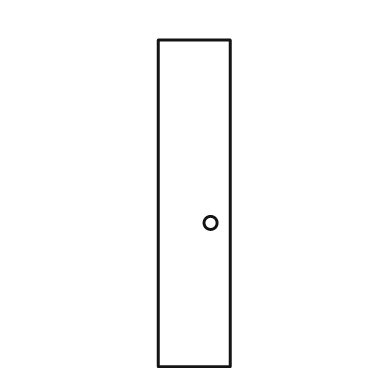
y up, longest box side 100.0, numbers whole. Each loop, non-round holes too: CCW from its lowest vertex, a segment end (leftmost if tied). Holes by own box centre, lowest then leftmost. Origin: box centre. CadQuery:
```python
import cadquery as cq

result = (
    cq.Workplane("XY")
    .moveTo(-11.0, -50.0)
    .lineTo(11.0, -50.0)
    .lineTo(11.0, 50.0)
    .lineTo(-11.0, 50.0)
    .close()
    .moveTo(5.0, -6.0)
    .circle(2.0)
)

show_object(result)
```